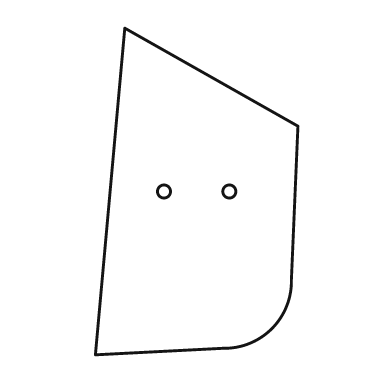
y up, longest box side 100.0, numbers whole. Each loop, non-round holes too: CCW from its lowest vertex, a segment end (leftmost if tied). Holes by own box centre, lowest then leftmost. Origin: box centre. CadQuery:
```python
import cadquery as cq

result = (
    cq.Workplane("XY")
    .moveTo(-31.0, -50.0)
    .lineTo(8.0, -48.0)
    .threePointArc((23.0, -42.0), (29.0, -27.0))
    .lineTo(31.0, 20.0)
    .lineTo(-22.0, 50.0)
    .close()
    .moveTo(-10.0, 0.0)
    .circle(2.0)
    .moveTo(10.0, 0.0)
    .circle(2.0)
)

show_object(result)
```